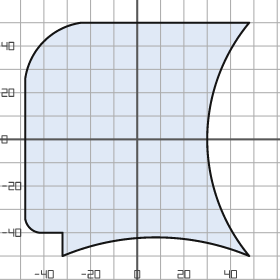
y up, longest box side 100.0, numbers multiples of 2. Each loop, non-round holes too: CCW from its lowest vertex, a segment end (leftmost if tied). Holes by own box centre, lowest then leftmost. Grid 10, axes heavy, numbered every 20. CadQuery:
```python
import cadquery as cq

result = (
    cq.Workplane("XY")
    .moveTo(-32.0, -50.0)
    .threePointArc((8.0, -42.0), (48.0, -50.0))
    .threePointArc((30.0, 0.0), (48.0, 50.0))
    .lineTo(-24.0, 50.0)
    .threePointArc((-40.0, 42.0), (-48.0, 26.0))
    .lineTo(-48.0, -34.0)
    .threePointArc((-46.0, -38.0), (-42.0, -40.0))
    .lineTo(-32.0, -40.0)
    .close()
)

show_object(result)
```